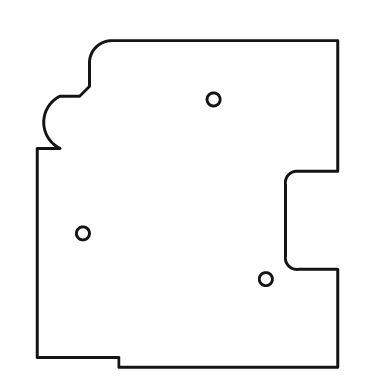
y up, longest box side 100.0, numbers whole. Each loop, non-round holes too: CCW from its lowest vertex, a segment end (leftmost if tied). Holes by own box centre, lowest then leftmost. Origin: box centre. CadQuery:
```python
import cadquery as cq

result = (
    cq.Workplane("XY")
    .moveTo(-21.0, -50.0)
    .lineTo(46.0, -50.0)
    .lineTo(46.0, -20.0)
    .lineTo(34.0, -20.0)
    .threePointArc((31.0, -19.0), (30.0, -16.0))
    .lineTo(30.0, 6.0)
    .threePointArc((31.0, 9.0), (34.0, 10.0))
    .lineTo(46.0, 10.0)
    .lineTo(46.0, 50.0)
    .lineTo(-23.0, 50.0)
    .threePointArc((-28.0, 48.0), (-30.0, 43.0))
    .lineTo(-30.0, 36.0)
    .lineTo(-33.0, 33.0)
    .lineTo(-39.0, 33.0)
    .threePointArc((-44.0, 25.0), (-39.0, 17.0))
    .lineTo(-46.0, 17.0)
    .lineTo(-46.0, -47.0)
    .lineTo(-21.0, -47.0)
    .close()
    .moveTo(24.0, -23.0)
    .circle(2.0)
    .moveTo(-32.0, -9.0)
    .circle(2.0)
    .moveTo(8.0, 32.0)
    .circle(2.0)
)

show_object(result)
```